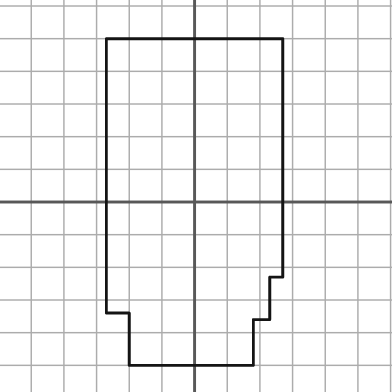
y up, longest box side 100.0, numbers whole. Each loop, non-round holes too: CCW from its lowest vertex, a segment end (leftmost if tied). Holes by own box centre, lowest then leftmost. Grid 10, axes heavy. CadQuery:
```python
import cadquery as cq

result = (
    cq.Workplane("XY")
    .moveTo(-20.0, -50.0)
    .lineTo(18.0, -50.0)
    .lineTo(18.0, -36.0)
    .lineTo(23.0, -36.0)
    .lineTo(23.0, -23.0)
    .lineTo(27.0, -23.0)
    .lineTo(27.0, 50.0)
    .lineTo(-27.0, 50.0)
    .lineTo(-27.0, -34.0)
    .lineTo(-20.0, -34.0)
    .close()
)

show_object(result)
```